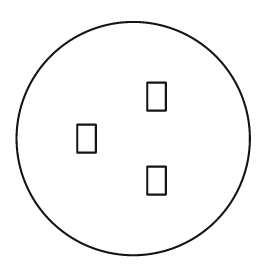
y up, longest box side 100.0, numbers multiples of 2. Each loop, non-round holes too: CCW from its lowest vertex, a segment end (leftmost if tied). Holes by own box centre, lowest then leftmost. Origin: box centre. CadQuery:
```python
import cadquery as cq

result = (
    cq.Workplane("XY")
    .moveTo(0.0, 0.0)
    .circle(50.0)
    .moveTo(6.0, -24.0)
    .lineTo(14.0, -24.0)
    .lineTo(14.0, -12.0)
    .lineTo(6.0, -12.0)
    .close()
    .moveTo(-24.0, -6.0)
    .lineTo(-16.0, -6.0)
    .lineTo(-16.0, 6.0)
    .lineTo(-24.0, 6.0)
    .close()
    .moveTo(6.0, 12.0)
    .lineTo(14.0, 12.0)
    .lineTo(14.0, 24.0)
    .lineTo(6.0, 24.0)
    .close()
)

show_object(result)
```